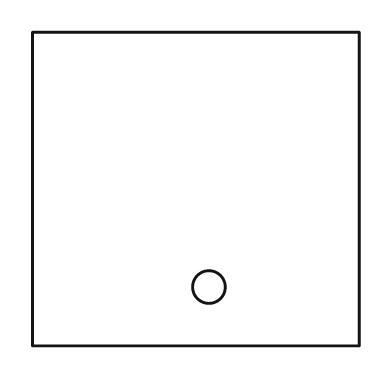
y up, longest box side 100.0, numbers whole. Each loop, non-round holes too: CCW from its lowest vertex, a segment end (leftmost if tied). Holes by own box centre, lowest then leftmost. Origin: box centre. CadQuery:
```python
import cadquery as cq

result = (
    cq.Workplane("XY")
    .moveTo(-50.0, -48.0)
    .lineTo(50.0, -48.0)
    .lineTo(50.0, 48.0)
    .lineTo(-50.0, 48.0)
    .close()
    .moveTo(4.0, -30.0)
    .circle(5.0)
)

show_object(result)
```